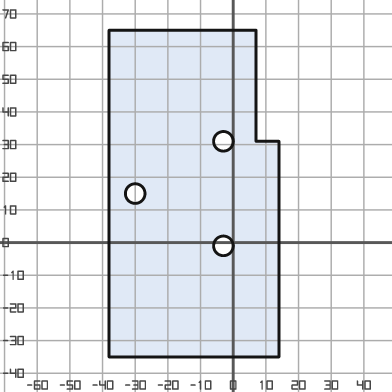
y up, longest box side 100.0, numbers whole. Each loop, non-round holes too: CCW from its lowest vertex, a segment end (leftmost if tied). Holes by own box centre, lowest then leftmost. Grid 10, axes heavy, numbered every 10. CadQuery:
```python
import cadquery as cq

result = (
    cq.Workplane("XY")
    .moveTo(-38.0, -35.0)
    .lineTo(14.0, -35.0)
    .lineTo(14.0, 31.0)
    .lineTo(7.0, 31.0)
    .lineTo(7.0, 65.0)
    .lineTo(-38.0, 65.0)
    .close()
    .moveTo(-3.0, -1.0)
    .circle(3.0)
    .moveTo(-30.0, 15.0)
    .circle(3.0)
    .moveTo(-3.0, 31.0)
    .circle(3.0)
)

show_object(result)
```